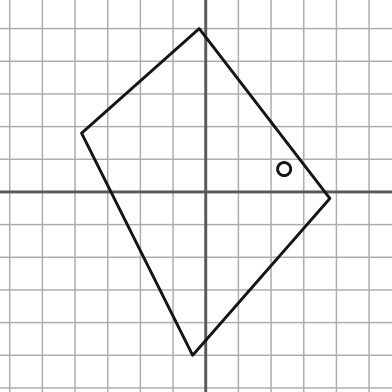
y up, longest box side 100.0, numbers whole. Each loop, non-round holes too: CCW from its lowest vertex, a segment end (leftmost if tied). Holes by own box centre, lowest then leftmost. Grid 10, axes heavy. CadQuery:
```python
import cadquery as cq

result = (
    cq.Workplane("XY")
    .moveTo(-4.0, -50.0)
    .lineTo(38.0, -2.0)
    .lineTo(-2.0, 50.0)
    .lineTo(-38.0, 18.0)
    .close()
    .moveTo(24.0, 7.0)
    .circle(2.0)
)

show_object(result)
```